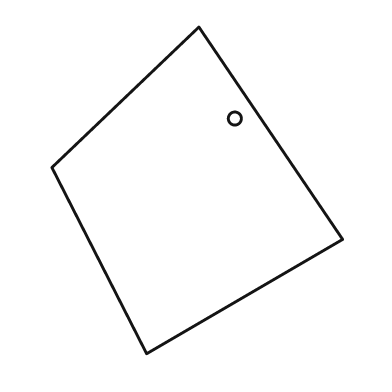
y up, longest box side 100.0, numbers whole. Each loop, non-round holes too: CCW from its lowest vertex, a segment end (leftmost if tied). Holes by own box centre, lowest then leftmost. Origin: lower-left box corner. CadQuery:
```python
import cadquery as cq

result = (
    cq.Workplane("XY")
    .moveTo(29.0, 0.0)
    .lineTo(89.0, 35.0)
    .lineTo(45.0, 100.0)
    .lineTo(0.0, 57.0)
    .close()
    .moveTo(56.0, 72.0)
    .circle(2.0)
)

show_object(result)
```